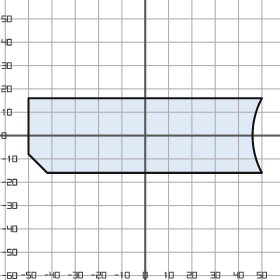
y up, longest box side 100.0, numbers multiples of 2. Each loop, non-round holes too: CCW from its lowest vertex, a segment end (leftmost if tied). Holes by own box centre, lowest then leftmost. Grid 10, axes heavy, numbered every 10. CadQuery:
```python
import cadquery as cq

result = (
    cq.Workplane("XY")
    .moveTo(-42.0, -16.0)
    .lineTo(50.0, -16.0)
    .threePointArc((46.0, 0.0), (50.0, 16.0))
    .lineTo(-50.0, 16.0)
    .lineTo(-50.0, -8.0)
    .close()
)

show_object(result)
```